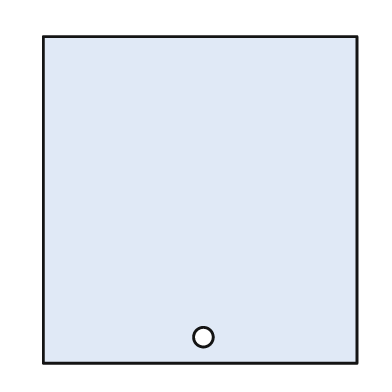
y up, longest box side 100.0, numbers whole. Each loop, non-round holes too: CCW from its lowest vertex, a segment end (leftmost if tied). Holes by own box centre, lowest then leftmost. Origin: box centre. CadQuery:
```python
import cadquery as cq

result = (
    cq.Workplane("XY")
    .moveTo(-48.0, -50.0)
    .lineTo(48.0, -50.0)
    .lineTo(48.0, 50.0)
    .lineTo(-48.0, 50.0)
    .close()
    .moveTo(1.0, -42.0)
    .circle(3.0)
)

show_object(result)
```